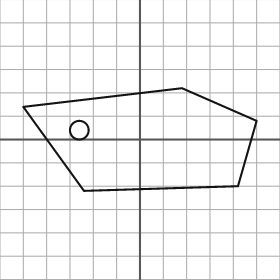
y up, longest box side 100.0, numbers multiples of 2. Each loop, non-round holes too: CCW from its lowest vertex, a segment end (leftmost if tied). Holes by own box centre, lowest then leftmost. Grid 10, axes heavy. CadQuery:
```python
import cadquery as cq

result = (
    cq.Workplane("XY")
    .moveTo(-24.0, -22.0)
    .lineTo(42.0, -20.0)
    .lineTo(50.0, 8.0)
    .lineTo(18.0, 22.0)
    .lineTo(-50.0, 14.0)
    .close()
    .moveTo(-26.0, 4.0)
    .circle(4.0)
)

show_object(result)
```